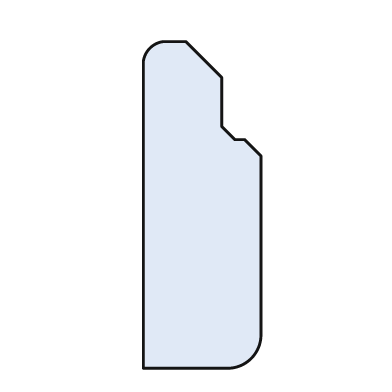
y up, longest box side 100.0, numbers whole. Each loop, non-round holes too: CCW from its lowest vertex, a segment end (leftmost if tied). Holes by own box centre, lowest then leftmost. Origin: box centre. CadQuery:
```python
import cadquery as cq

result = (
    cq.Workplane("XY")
    .moveTo(-18.0, -50.0)
    .lineTo(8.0, -50.0)
    .threePointArc((15.0, -47.0), (18.0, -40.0))
    .lineTo(18.0, 15.0)
    .lineTo(13.0, 20.0)
    .lineTo(10.0, 20.0)
    .lineTo(6.0, 24.0)
    .lineTo(6.0, 39.0)
    .lineTo(-5.0, 50.0)
    .lineTo(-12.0, 50.0)
    .threePointArc((-16.0, 48.0), (-18.0, 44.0))
    .close()
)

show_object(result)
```